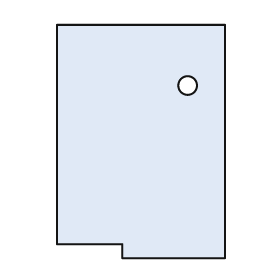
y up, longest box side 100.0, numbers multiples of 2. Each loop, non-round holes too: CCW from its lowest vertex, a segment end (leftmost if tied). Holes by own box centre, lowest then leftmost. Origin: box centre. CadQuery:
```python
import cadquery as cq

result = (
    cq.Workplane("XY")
    .moveTo(-8.0, -50.0)
    .lineTo(36.0, -50.0)
    .lineTo(36.0, 50.0)
    .lineTo(-36.0, 50.0)
    .lineTo(-36.0, -44.0)
    .lineTo(-8.0, -44.0)
    .close()
    .moveTo(20.0, 24.0)
    .circle(4.0)
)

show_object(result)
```